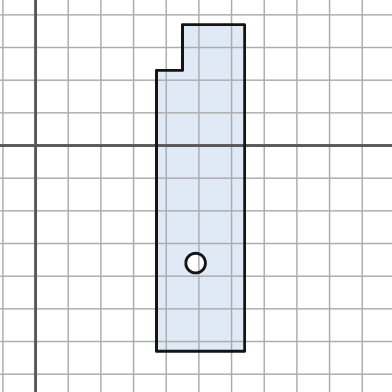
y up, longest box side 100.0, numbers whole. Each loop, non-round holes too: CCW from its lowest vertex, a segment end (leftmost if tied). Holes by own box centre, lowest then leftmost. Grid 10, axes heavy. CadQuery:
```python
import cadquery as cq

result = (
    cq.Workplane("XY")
    .moveTo(37.0, -63.0)
    .lineTo(64.0, -63.0)
    .lineTo(64.0, 37.0)
    .lineTo(45.0, 37.0)
    .lineTo(45.0, 23.0)
    .lineTo(37.0, 23.0)
    .close()
    .moveTo(49.0, -36.0)
    .circle(3.0)
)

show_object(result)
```